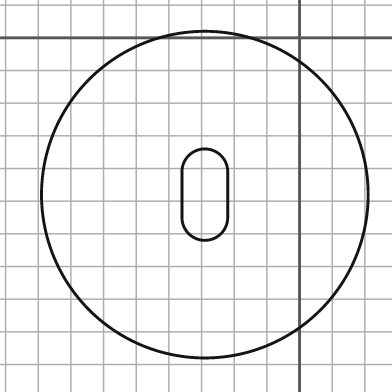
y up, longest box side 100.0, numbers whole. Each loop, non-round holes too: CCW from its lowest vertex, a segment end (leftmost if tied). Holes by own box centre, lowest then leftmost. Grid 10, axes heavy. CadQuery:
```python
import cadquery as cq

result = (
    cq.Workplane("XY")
    .moveTo(-29.0, -48.0)
    .circle(50.0)
    .moveTo(-36.0, -55.0)
    .threePointArc((-29.0, -62.0), (-22.0, -55.0))
    .lineTo(-22.0, -41.0)
    .threePointArc((-29.0, -34.0), (-36.0, -41.0))
    .close()
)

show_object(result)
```